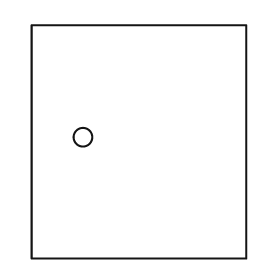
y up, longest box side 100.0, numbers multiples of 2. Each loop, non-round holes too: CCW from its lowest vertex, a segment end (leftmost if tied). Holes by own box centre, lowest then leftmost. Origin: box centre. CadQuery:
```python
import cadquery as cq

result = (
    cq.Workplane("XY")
    .moveTo(-46.0, -50.0)
    .lineTo(46.0, -50.0)
    .lineTo(46.0, 50.0)
    .lineTo(-46.0, 50.0)
    .close()
    .moveTo(-24.0, 2.0)
    .circle(4.0)
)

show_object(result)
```